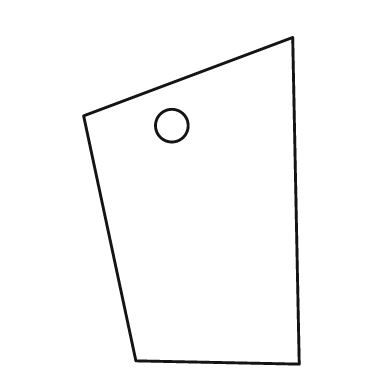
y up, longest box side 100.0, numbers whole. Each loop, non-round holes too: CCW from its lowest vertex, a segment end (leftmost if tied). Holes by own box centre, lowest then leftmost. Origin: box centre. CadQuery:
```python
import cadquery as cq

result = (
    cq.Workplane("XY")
    .moveTo(33.0, -50.0)
    .lineTo(31.0, 50.0)
    .lineTo(-33.0, 26.0)
    .lineTo(-17.0, -49.0)
    .close()
    .moveTo(-6.0, 23.0)
    .circle(5.0)
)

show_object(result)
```